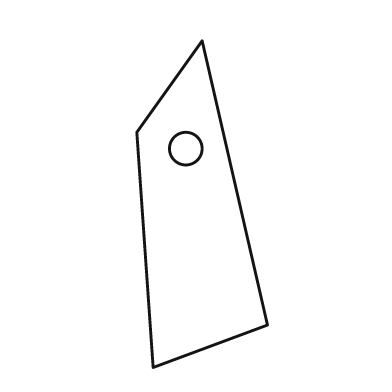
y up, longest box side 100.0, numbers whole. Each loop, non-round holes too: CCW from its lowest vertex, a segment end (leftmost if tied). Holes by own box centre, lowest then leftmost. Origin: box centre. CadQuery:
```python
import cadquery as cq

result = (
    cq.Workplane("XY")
    .moveTo(-15.0, -50.0)
    .lineTo(20.0, -37.0)
    .lineTo(0.0, 50.0)
    .lineTo(-20.0, 22.0)
    .close()
    .moveTo(-5.0, 17.0)
    .circle(5.0)
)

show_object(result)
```